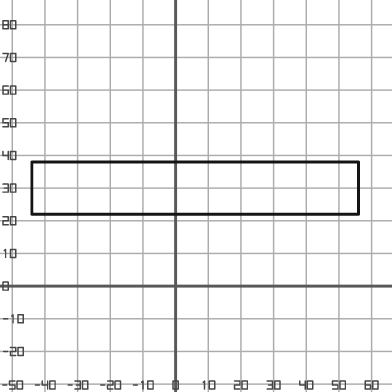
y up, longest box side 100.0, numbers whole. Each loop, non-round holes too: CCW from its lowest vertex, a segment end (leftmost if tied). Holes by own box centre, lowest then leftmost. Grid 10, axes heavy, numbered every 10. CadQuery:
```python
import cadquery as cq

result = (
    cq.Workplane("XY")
    .moveTo(-44.0, 22.0)
    .lineTo(56.0, 22.0)
    .lineTo(56.0, 38.0)
    .lineTo(-44.0, 38.0)
    .close()
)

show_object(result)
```